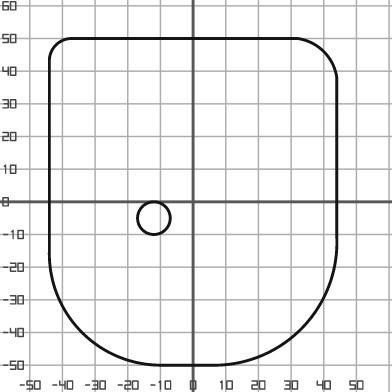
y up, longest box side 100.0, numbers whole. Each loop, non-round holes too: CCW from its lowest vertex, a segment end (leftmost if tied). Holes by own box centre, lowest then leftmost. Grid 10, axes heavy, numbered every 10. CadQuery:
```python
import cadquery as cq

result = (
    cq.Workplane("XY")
    .moveTo(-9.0, -50.0)
    .lineTo(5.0, -50.0)
    .threePointArc((33.0, -39.0), (44.0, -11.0))
    .lineTo(44.0, 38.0)
    .threePointArc((40.0, 46.0), (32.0, 50.0))
    .lineTo(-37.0, 50.0)
    .threePointArc((-42.0, 48.0), (-44.0, 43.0))
    .lineTo(-44.0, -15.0)
    .threePointArc((-34.0, -40.0), (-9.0, -50.0))
    .close()
    .moveTo(-12.0, -5.0)
    .circle(5.0)
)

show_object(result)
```